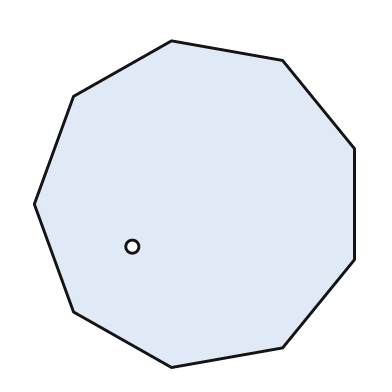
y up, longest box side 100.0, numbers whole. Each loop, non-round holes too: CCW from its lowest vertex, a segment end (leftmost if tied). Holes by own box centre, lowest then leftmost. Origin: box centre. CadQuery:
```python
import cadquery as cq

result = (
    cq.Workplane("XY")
    .moveTo(-7.0, -50.0)
    .lineTo(27.0, -44.0)
    .lineTo(49.0, -17.0)
    .lineTo(49.0, 17.0)
    .lineTo(27.0, 44.0)
    .lineTo(-7.0, 50.0)
    .lineTo(-37.0, 33.0)
    .lineTo(-49.0, 0.0)
    .lineTo(-37.0, -33.0)
    .close()
    .moveTo(-19.0, -13.0)
    .circle(2.0)
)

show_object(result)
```